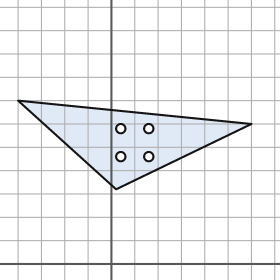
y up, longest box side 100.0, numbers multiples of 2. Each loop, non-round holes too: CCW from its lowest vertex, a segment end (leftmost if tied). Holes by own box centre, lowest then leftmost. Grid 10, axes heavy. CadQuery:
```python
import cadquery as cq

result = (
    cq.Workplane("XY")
    .moveTo(2.0, 32.0)
    .lineTo(60.0, 60.0)
    .lineTo(-40.0, 70.0)
    .close()
    .moveTo(4.0, 46.0)
    .circle(2.0)
    .moveTo(16.0, 46.0)
    .circle(2.0)
    .moveTo(4.0, 58.0)
    .circle(2.0)
    .moveTo(16.0, 58.0)
    .circle(2.0)
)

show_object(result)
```